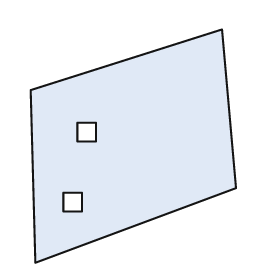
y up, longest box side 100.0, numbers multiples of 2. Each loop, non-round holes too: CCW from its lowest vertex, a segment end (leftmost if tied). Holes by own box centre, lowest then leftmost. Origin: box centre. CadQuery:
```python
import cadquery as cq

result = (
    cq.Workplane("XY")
    .moveTo(-42.0, -50.0)
    .lineTo(44.0, -18.0)
    .lineTo(38.0, 50.0)
    .lineTo(-44.0, 24.0)
    .close()
    .moveTo(-30.0, -28.0)
    .lineTo(-22.0, -28.0)
    .lineTo(-22.0, -20.0)
    .lineTo(-30.0, -20.0)
    .close()
    .moveTo(-24.0, 2.0)
    .lineTo(-16.0, 2.0)
    .lineTo(-16.0, 10.0)
    .lineTo(-24.0, 10.0)
    .close()
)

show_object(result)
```